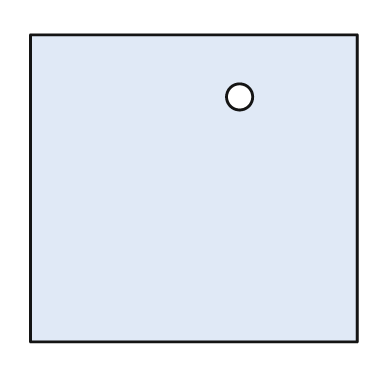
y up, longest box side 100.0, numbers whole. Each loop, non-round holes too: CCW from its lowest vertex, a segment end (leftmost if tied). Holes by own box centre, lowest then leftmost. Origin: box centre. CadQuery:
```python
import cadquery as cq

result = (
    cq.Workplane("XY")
    .moveTo(-50.0, -47.0)
    .lineTo(50.0, -47.0)
    .lineTo(50.0, 47.0)
    .lineTo(-50.0, 47.0)
    .close()
    .moveTo(14.0, 28.0)
    .circle(4.0)
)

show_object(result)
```